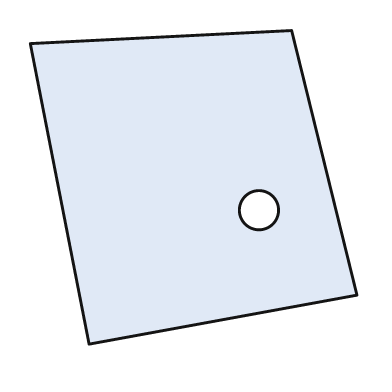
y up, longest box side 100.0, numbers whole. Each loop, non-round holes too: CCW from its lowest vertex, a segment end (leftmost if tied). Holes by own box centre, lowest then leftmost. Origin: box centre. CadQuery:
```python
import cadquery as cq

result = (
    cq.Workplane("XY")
    .moveTo(-32.0, -48.0)
    .lineTo(50.0, -33.0)
    .lineTo(30.0, 48.0)
    .lineTo(-50.0, 44.0)
    .close()
    .moveTo(20.0, -7.0)
    .circle(6.0)
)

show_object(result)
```